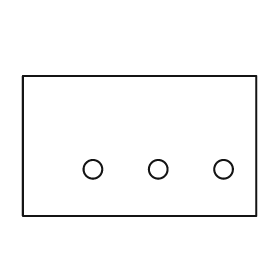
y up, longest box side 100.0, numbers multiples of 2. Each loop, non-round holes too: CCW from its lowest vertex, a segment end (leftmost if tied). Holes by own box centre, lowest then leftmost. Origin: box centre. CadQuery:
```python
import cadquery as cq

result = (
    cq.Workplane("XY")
    .moveTo(-50.0, -30.0)
    .lineTo(50.0, -30.0)
    .lineTo(50.0, 30.0)
    .lineTo(-50.0, 30.0)
    .close()
    .moveTo(-20.0, -10.0)
    .circle(4.0)
    .moveTo(8.0, -10.0)
    .circle(4.0)
    .moveTo(36.0, -10.0)
    .circle(4.0)
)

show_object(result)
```